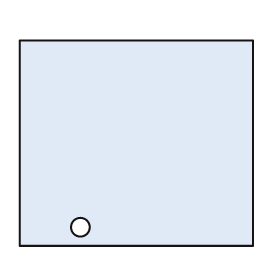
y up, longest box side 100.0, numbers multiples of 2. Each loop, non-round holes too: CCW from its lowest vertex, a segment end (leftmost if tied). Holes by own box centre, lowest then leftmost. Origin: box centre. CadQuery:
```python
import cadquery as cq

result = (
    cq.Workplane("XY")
    .moveTo(-50.0, -44.0)
    .lineTo(50.0, -44.0)
    .lineTo(50.0, 44.0)
    .lineTo(-50.0, 44.0)
    .close()
    .moveTo(-24.0, -36.0)
    .circle(4.0)
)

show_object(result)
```